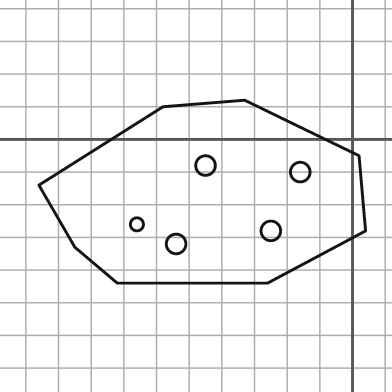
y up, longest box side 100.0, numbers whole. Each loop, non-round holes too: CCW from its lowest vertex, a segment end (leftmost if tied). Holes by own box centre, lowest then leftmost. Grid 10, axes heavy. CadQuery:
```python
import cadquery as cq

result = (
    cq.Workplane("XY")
    .moveTo(-72.0, -44.0)
    .lineTo(-26.0, -44.0)
    .lineTo(4.0, -28.0)
    .lineTo(2.0, -5.0)
    .lineTo(-33.0, 12.0)
    .lineTo(-58.0, 10.0)
    .lineTo(-96.0, -14.0)
    .lineTo(-85.0, -33.0)
    .close()
    .moveTo(-54.0, -32.0)
    .circle(3.0)
    .moveTo(-25.0, -28.0)
    .circle(3.0)
    .moveTo(-66.0, -26.0)
    .circle(2.0)
    .moveTo(-16.0, -10.0)
    .circle(3.0)
    .moveTo(-45.0, -8.0)
    .circle(3.0)
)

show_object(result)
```